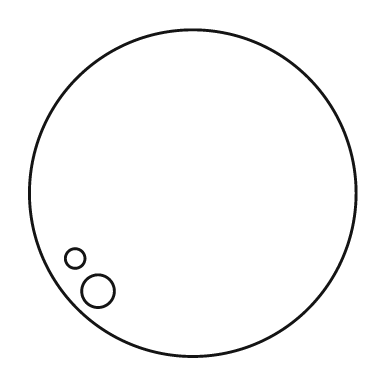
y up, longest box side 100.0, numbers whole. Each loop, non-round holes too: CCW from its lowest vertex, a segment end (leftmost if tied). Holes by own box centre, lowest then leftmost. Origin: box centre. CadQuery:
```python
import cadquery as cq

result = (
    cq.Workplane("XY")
    .moveTo(0.0, 0.0)
    .circle(50.0)
    .moveTo(-29.0, -30.0)
    .circle(5.0)
    .moveTo(-36.0, -20.0)
    .circle(3.0)
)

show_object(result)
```